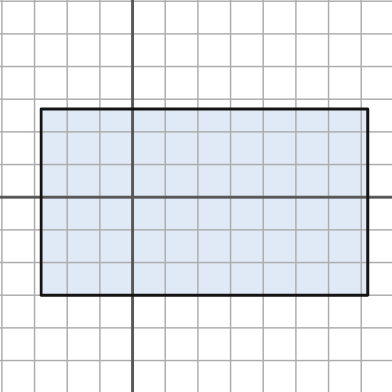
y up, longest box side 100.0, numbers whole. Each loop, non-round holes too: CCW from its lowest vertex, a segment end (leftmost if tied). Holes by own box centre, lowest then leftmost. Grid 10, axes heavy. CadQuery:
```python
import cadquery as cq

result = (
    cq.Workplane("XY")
    .moveTo(-28.0, -30.0)
    .lineTo(72.0, -30.0)
    .lineTo(72.0, 27.0)
    .lineTo(-28.0, 27.0)
    .close()
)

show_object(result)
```